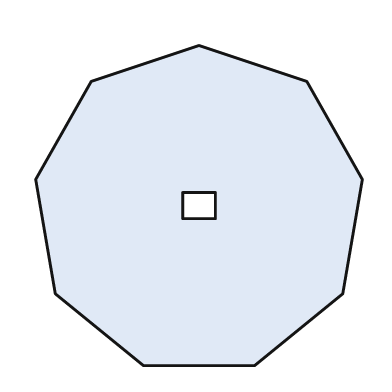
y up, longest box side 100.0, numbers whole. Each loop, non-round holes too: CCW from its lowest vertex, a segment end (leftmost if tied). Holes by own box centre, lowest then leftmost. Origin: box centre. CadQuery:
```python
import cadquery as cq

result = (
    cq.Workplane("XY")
    .moveTo(-17.0, -49.0)
    .lineTo(17.0, -49.0)
    .lineTo(44.0, -27.0)
    .lineTo(50.0, 8.0)
    .lineTo(33.0, 38.0)
    .lineTo(0.0, 49.0)
    .lineTo(-33.0, 38.0)
    .lineTo(-50.0, 8.0)
    .lineTo(-44.0, -27.0)
    .close()
    .moveTo(-5.0, -4.0)
    .lineTo(5.0, -4.0)
    .lineTo(5.0, 4.0)
    .lineTo(-5.0, 4.0)
    .close()
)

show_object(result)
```